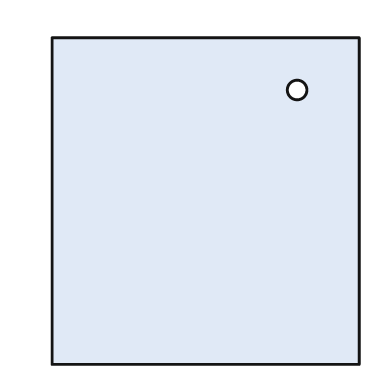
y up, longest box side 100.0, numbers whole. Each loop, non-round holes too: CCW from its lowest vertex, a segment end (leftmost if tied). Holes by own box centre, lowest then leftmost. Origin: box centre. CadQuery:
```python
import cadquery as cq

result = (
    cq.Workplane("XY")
    .moveTo(-47.0, -50.0)
    .lineTo(47.0, -50.0)
    .lineTo(47.0, 50.0)
    .lineTo(-47.0, 50.0)
    .close()
    .moveTo(28.0, 34.0)
    .circle(3.0)
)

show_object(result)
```